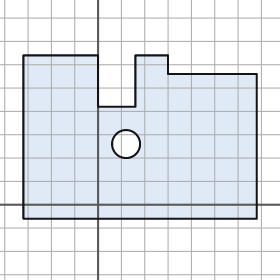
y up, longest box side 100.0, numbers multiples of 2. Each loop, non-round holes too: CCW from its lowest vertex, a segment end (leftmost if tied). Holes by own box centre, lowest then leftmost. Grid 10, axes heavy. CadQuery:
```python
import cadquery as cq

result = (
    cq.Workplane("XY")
    .moveTo(-32.0, -6.0)
    .lineTo(68.0, -6.0)
    .lineTo(68.0, 56.0)
    .lineTo(30.0, 56.0)
    .lineTo(30.0, 64.0)
    .lineTo(16.0, 64.0)
    .lineTo(16.0, 42.0)
    .lineTo(0.0, 42.0)
    .lineTo(0.0, 64.0)
    .lineTo(-32.0, 64.0)
    .close()
    .moveTo(12.0, 26.0)
    .circle(6.0)
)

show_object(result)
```